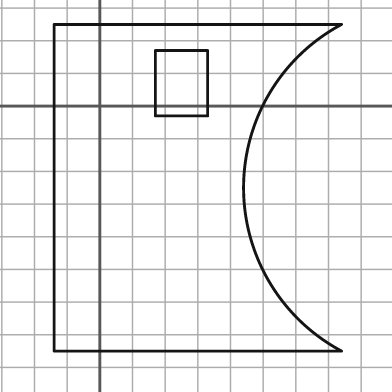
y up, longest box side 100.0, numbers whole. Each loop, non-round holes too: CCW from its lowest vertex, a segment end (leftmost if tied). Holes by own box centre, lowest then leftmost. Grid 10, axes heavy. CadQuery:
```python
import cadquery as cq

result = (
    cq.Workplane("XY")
    .moveTo(-14.0, -75.0)
    .lineTo(74.0, -75.0)
    .threePointArc((44.0, -25.0), (74.0, 25.0))
    .lineTo(-14.0, 25.0)
    .close()
    .moveTo(17.0, -3.0)
    .lineTo(33.0, -3.0)
    .lineTo(33.0, 17.0)
    .lineTo(17.0, 17.0)
    .close()
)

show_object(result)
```